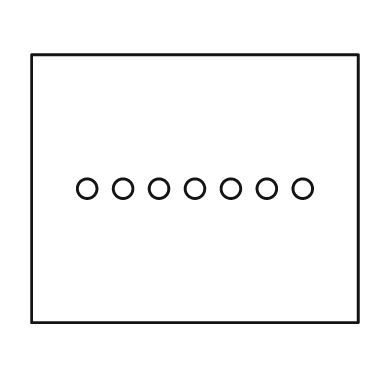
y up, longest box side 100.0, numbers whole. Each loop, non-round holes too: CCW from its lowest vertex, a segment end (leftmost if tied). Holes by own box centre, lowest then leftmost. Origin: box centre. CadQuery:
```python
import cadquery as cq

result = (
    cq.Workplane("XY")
    .moveTo(-50.0, -41.0)
    .lineTo(50.0, -41.0)
    .lineTo(50.0, 41.0)
    .lineTo(-50.0, 41.0)
    .close()
    .moveTo(-33.0, 0.0)
    .circle(3.0)
    .moveTo(-22.0, 0.0)
    .circle(3.0)
    .moveTo(-11.0, 0.0)
    .circle(3.0)
    .moveTo(0.0, 0.0)
    .circle(3.0)
    .moveTo(11.0, 0.0)
    .circle(3.0)
    .moveTo(22.0, 0.0)
    .circle(3.0)
    .moveTo(33.0, 0.0)
    .circle(3.0)
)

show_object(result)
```